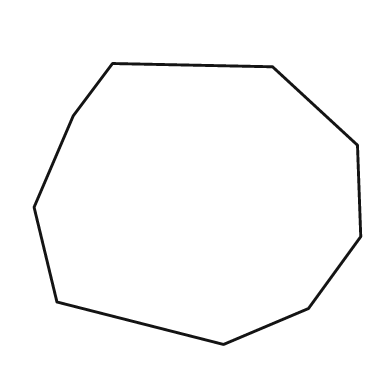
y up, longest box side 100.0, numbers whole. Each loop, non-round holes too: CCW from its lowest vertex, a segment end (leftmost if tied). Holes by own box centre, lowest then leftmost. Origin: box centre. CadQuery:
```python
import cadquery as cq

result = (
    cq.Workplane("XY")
    .moveTo(8.0, -43.0)
    .lineTo(34.0, -32.0)
    .lineTo(50.0, -10.0)
    .lineTo(49.0, 18.0)
    .lineTo(23.0, 42.0)
    .lineTo(-26.0, 43.0)
    .lineTo(-38.0, 27.0)
    .lineTo(-50.0, -1.0)
    .lineTo(-43.0, -30.0)
    .close()
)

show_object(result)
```